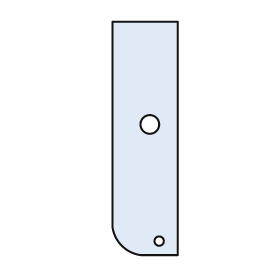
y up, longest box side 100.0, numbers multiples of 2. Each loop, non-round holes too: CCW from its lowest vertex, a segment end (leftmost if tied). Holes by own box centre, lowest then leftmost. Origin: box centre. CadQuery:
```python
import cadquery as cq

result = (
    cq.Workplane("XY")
    .moveTo(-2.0, -50.0)
    .lineTo(14.0, -50.0)
    .lineTo(14.0, 50.0)
    .lineTo(-14.0, 50.0)
    .lineTo(-14.0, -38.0)
    .threePointArc((-10.0, -46.0), (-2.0, -50.0))
    .close()
    .moveTo(6.0, -44.0)
    .circle(2.0)
    .moveTo(2.0, 6.0)
    .circle(4.0)
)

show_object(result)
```